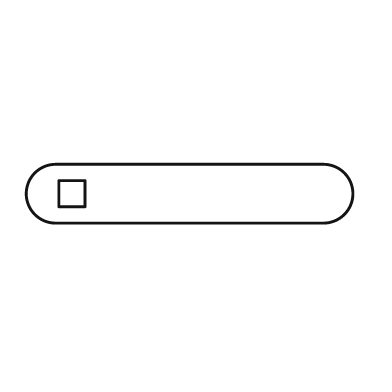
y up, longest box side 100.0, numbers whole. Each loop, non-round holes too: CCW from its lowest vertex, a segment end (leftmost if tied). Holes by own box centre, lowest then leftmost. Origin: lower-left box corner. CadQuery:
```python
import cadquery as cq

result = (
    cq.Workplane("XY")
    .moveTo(9.0, 0.0)
    .lineTo(91.0, 0.0)
    .threePointArc((100.0, 9.0), (91.0, 18.0))
    .lineTo(9.0, 18.0)
    .threePointArc((0.0, 9.0), (9.0, 0.0))
    .close()
    .moveTo(10.0, 5.0)
    .lineTo(18.0, 5.0)
    .lineTo(18.0, 13.0)
    .lineTo(10.0, 13.0)
    .close()
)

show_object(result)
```